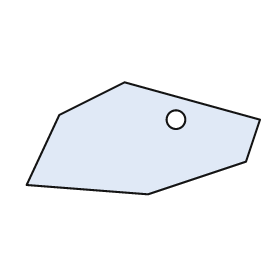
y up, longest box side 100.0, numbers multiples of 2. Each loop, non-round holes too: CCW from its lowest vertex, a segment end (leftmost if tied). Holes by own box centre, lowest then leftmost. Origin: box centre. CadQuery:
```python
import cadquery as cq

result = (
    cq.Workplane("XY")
    .moveTo(2.0, -24.0)
    .lineTo(44.0, -10.0)
    .lineTo(50.0, 8.0)
    .lineTo(-8.0, 24.0)
    .lineTo(-36.0, 10.0)
    .lineTo(-50.0, -20.0)
    .close()
    .moveTo(14.0, 8.0)
    .circle(4.0)
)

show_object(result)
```